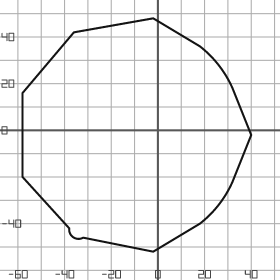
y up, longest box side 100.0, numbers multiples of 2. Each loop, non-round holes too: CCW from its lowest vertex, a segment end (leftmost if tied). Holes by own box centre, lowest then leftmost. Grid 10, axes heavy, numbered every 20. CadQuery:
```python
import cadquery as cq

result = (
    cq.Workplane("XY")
    .moveTo(-2.0, -52.0)
    .lineTo(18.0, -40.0)
    .threePointArc((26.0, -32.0), (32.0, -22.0))
    .lineTo(40.0, -2.0)
    .lineTo(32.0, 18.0)
    .threePointArc((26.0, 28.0), (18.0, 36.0))
    .lineTo(-2.0, 48.0)
    .lineTo(-36.0, 42.0)
    .lineTo(-58.0, 16.0)
    .lineTo(-58.0, -20.0)
    .lineTo(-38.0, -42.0)
    .threePointArc((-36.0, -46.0), (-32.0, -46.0))
    .close()
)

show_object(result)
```